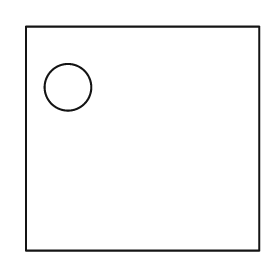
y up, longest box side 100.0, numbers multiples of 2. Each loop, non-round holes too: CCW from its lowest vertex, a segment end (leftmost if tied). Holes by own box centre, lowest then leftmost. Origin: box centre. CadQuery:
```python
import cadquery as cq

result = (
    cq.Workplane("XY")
    .moveTo(-50.0, -48.0)
    .lineTo(50.0, -48.0)
    .lineTo(50.0, 48.0)
    .lineTo(-50.0, 48.0)
    .close()
    .moveTo(-32.0, 22.0)
    .circle(10.0)
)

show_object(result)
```